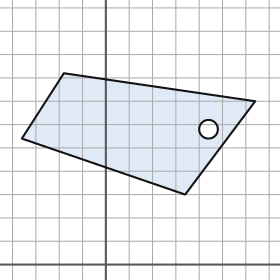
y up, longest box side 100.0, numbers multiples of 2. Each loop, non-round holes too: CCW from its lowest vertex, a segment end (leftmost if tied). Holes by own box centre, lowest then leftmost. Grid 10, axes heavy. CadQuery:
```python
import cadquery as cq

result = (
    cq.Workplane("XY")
    .moveTo(34.0, 30.0)
    .lineTo(64.0, 70.0)
    .lineTo(-18.0, 82.0)
    .lineTo(-36.0, 54.0)
    .close()
    .moveTo(44.0, 58.0)
    .circle(4.0)
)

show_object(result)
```